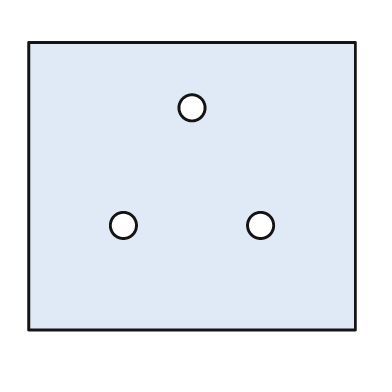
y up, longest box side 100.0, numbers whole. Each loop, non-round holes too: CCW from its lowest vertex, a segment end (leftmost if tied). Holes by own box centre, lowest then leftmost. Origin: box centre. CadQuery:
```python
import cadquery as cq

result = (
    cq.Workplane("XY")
    .moveTo(-50.0, -44.0)
    .lineTo(50.0, -44.0)
    .lineTo(50.0, 44.0)
    .lineTo(-50.0, 44.0)
    .close()
    .moveTo(-21.0, -12.0)
    .circle(4.0)
    .moveTo(21.0, -12.0)
    .circle(4.0)
    .moveTo(0.0, 24.0)
    .circle(4.0)
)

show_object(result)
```